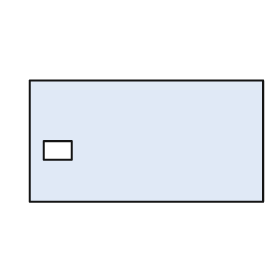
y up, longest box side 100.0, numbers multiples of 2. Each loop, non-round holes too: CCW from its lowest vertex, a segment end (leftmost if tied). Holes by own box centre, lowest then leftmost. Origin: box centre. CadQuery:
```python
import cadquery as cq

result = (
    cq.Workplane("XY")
    .moveTo(-50.0, -26.0)
    .lineTo(50.0, -26.0)
    .lineTo(50.0, 26.0)
    .lineTo(-50.0, 26.0)
    .close()
    .moveTo(-44.0, -8.0)
    .lineTo(-32.0, -8.0)
    .lineTo(-32.0, 0.0)
    .lineTo(-44.0, 0.0)
    .close()
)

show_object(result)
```